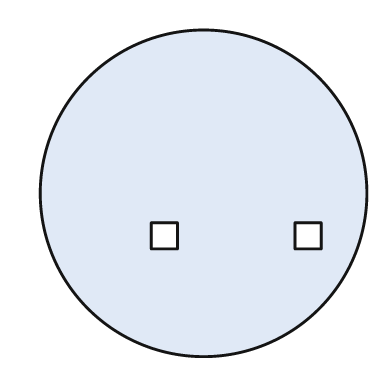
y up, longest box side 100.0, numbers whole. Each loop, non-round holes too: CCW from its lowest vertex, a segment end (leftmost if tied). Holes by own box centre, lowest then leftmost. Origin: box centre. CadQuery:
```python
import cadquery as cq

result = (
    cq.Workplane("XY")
    .moveTo(0.0, 0.0)
    .circle(50.0)
    .moveTo(-16.0, -17.0)
    .lineTo(-8.0, -17.0)
    .lineTo(-8.0, -9.0)
    .lineTo(-16.0, -9.0)
    .close()
    .moveTo(28.0, -17.0)
    .lineTo(36.0, -17.0)
    .lineTo(36.0, -9.0)
    .lineTo(28.0, -9.0)
    .close()
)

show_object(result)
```